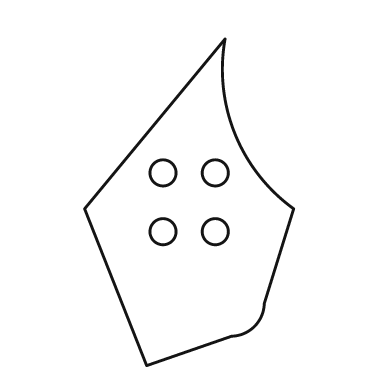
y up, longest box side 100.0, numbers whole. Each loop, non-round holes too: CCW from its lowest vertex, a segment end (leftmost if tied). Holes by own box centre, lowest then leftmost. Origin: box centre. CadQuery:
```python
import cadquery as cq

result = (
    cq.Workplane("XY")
    .moveTo(-13.0, -50.0)
    .lineTo(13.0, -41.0)
    .threePointArc((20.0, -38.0), (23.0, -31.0))
    .lineTo(32.0, -2.0)
    .threePointArc((14.0, 21.0), (11.0, 50.0))
    .lineTo(-32.0, -2.0)
    .close()
    .moveTo(-8.0, -9.0)
    .circle(4.0)
    .moveTo(8.0, -9.0)
    .circle(4.0)
    .moveTo(-8.0, 9.0)
    .circle(4.0)
    .moveTo(8.0, 9.0)
    .circle(4.0)
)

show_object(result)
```